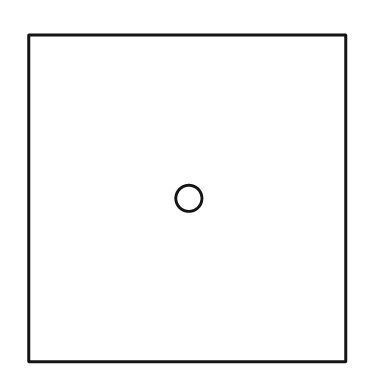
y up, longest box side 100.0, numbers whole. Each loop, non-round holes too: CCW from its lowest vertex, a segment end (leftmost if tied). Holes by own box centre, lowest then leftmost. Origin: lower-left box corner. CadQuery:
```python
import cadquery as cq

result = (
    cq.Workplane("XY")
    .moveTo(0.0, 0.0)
    .lineTo(97.0, 0.0)
    .lineTo(97.0, 100.0)
    .lineTo(0.0, 100.0)
    .close()
    .moveTo(49.0, 50.0)
    .circle(4.0)
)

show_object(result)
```